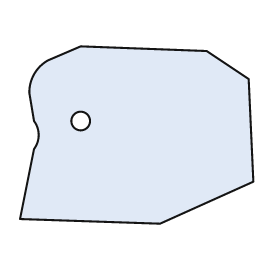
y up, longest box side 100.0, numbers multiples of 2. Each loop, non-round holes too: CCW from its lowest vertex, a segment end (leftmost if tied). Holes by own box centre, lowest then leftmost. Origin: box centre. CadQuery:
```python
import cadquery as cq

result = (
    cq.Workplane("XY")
    .moveTo(10.0, -38.0)
    .lineTo(50.0, -20.0)
    .lineTo(48.0, 24.0)
    .lineTo(30.0, 36.0)
    .lineTo(-24.0, 38.0)
    .lineTo(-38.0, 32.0)
    .threePointArc((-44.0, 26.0), (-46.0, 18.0))
    .lineTo(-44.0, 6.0)
    .threePointArc((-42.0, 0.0), (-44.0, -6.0))
    .lineTo(-50.0, -36.0)
    .close()
    .moveTo(-24.0, 6.0)
    .circle(4.0)
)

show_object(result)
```